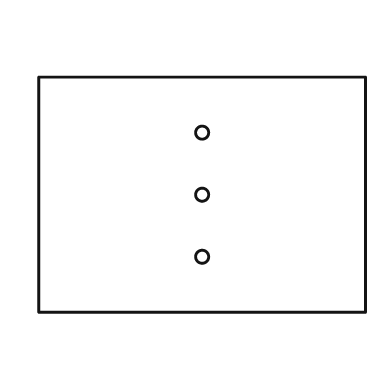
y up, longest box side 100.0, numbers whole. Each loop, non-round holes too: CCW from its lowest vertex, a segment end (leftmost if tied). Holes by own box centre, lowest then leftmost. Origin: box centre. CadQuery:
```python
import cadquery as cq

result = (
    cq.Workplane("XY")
    .moveTo(-50.0, -36.0)
    .lineTo(50.0, -36.0)
    .lineTo(50.0, 36.0)
    .lineTo(-50.0, 36.0)
    .close()
    .moveTo(0.0, -19.0)
    .circle(2.0)
    .moveTo(0.0, 0.0)
    .circle(2.0)
    .moveTo(0.0, 19.0)
    .circle(2.0)
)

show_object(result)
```